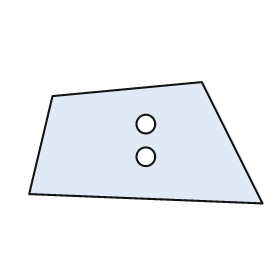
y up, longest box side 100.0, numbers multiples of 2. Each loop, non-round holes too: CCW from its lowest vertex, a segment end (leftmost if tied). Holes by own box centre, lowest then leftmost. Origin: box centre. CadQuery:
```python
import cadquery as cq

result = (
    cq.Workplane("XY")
    .moveTo(50.0, -26.0)
    .lineTo(24.0, 26.0)
    .lineTo(-40.0, 20.0)
    .lineTo(-50.0, -22.0)
    .close()
    .moveTo(0.0, -6.0)
    .circle(4.0)
    .moveTo(0.0, 8.0)
    .circle(4.0)
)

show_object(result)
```